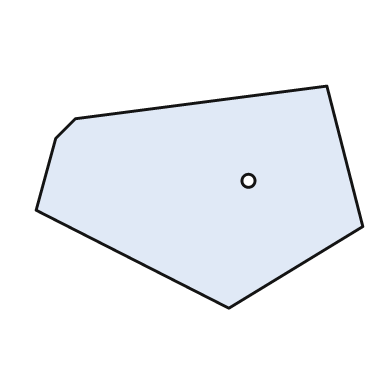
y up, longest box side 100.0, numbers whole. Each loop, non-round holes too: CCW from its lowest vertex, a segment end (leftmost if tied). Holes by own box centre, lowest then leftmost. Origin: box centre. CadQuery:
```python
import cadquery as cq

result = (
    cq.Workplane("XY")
    .moveTo(9.0, -34.0)
    .lineTo(50.0, -9.0)
    .lineTo(39.0, 34.0)
    .lineTo(-38.0, 24.0)
    .lineTo(-44.0, 18.0)
    .lineTo(-50.0, -4.0)
    .close()
    .moveTo(15.0, 5.0)
    .circle(2.0)
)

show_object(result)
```